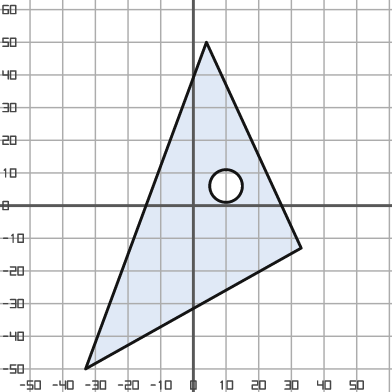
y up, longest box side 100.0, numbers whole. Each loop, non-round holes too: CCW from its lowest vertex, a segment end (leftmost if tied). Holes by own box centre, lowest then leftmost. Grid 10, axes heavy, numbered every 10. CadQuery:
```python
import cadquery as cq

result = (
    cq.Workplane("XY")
    .moveTo(-33.0, -50.0)
    .lineTo(33.0, -13.0)
    .lineTo(4.0, 50.0)
    .close()
    .moveTo(10.0, 6.0)
    .circle(5.0)
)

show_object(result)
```